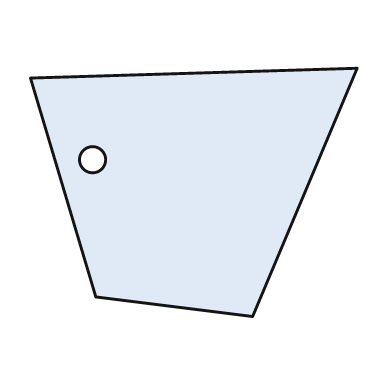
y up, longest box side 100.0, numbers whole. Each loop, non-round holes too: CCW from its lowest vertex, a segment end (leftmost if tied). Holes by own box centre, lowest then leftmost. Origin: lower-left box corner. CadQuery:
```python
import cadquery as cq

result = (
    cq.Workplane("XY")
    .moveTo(68.0, 0.0)
    .lineTo(100.0, 76.0)
    .lineTo(0.0, 73.0)
    .lineTo(20.0, 6.0)
    .close()
    .moveTo(19.0, 48.0)
    .circle(4.0)
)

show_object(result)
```